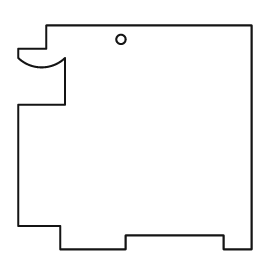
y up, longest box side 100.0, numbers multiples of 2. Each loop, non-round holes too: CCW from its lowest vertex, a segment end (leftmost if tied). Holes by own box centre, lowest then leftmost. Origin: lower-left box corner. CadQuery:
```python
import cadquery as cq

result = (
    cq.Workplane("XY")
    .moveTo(18.0, 0.0)
    .lineTo(46.0, 0.0)
    .lineTo(46.0, 6.0)
    .lineTo(88.0, 6.0)
    .lineTo(88.0, 0.0)
    .lineTo(100.0, 0.0)
    .lineTo(100.0, 96.0)
    .lineTo(12.0, 96.0)
    .lineTo(12.0, 86.0)
    .lineTo(0.0, 86.0)
    .lineTo(0.0, 82.0)
    .threePointArc((10.0, 78.0), (20.0, 82.0))
    .lineTo(20.0, 62.0)
    .lineTo(0.0, 62.0)
    .lineTo(0.0, 10.0)
    .lineTo(18.0, 10.0)
    .close()
    .moveTo(44.0, 90.0)
    .circle(2.0)
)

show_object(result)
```